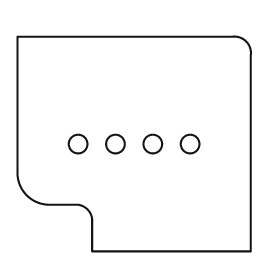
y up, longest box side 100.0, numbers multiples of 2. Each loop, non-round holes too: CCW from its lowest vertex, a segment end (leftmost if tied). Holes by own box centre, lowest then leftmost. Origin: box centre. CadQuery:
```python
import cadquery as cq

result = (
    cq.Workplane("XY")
    .moveTo(-18.0, -46.0)
    .lineTo(50.0, -46.0)
    .lineTo(50.0, 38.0)
    .threePointArc((48.0, 44.0), (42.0, 46.0))
    .lineTo(-50.0, 46.0)
    .lineTo(-50.0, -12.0)
    .threePointArc((-46.0, -22.0), (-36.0, -26.0))
    .lineTo(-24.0, -26.0)
    .threePointArc((-20.0, -28.0), (-18.0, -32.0))
    .close()
    .moveTo(-24.0, 0.0)
    .circle(4.0)
    .moveTo(-8.0, 0.0)
    .circle(4.0)
    .moveTo(8.0, 0.0)
    .circle(4.0)
    .moveTo(24.0, 0.0)
    .circle(4.0)
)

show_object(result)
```